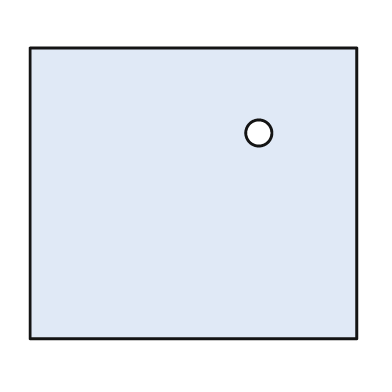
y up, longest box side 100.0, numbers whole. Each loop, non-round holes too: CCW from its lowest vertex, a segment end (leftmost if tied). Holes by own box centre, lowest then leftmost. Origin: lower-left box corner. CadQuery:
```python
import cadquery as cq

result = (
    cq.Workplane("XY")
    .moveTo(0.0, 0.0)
    .lineTo(100.0, 0.0)
    .lineTo(100.0, 89.0)
    .lineTo(0.0, 89.0)
    .close()
    .moveTo(70.0, 63.0)
    .circle(4.0)
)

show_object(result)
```